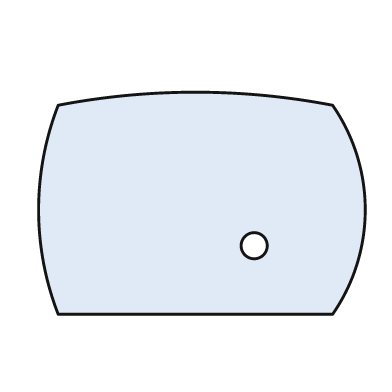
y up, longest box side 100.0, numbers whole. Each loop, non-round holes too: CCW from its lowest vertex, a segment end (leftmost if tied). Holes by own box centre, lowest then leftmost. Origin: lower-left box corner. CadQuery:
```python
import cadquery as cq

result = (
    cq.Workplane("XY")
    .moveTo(6.0, 0.0)
    .lineTo(90.0, 0.0)
    .threePointArc((100.0, 32.0), (90.0, 64.0))
    .threePointArc((48.0, 68.0), (6.0, 64.0))
    .threePointArc((0.0, 32.0), (6.0, 0.0))
    .close()
    .moveTo(66.0, 21.0)
    .circle(4.0)
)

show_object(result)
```